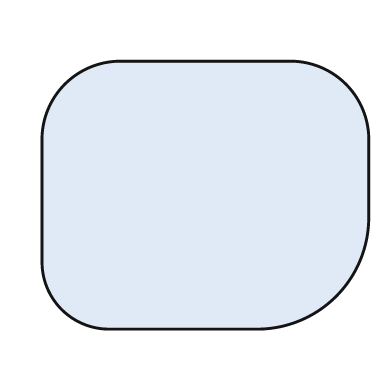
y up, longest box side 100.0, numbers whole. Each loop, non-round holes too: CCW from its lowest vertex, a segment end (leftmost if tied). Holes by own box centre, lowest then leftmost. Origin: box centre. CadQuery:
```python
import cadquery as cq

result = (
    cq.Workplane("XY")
    .moveTo(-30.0, -41.0)
    .lineTo(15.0, -41.0)
    .threePointArc((40.0, -31.0), (50.0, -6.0))
    .lineTo(50.0, 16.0)
    .threePointArc((43.0, 34.0), (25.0, 41.0))
    .lineTo(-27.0, 41.0)
    .threePointArc((-43.0, 34.0), (-50.0, 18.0))
    .lineTo(-50.0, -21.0)
    .threePointArc((-44.0, -35.0), (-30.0, -41.0))
    .close()
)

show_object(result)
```